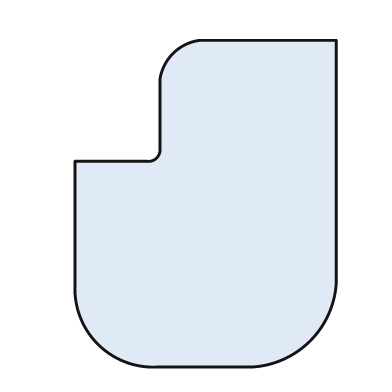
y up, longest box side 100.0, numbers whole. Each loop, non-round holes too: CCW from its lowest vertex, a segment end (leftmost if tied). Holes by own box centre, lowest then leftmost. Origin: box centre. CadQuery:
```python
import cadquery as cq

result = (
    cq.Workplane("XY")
    .moveTo(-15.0, -50.0)
    .lineTo(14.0, -50.0)
    .threePointArc((32.0, -42.0), (40.0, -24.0))
    .lineTo(40.0, 50.0)
    .lineTo(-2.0, 50.0)
    .threePointArc((-10.0, 46.0), (-14.0, 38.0))
    .lineTo(-14.0, 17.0)
    .threePointArc((-15.0, 14.0), (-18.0, 13.0))
    .lineTo(-40.0, 13.0)
    .lineTo(-40.0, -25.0)
    .threePointArc((-33.0, -43.0), (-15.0, -50.0))
    .close()
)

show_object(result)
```